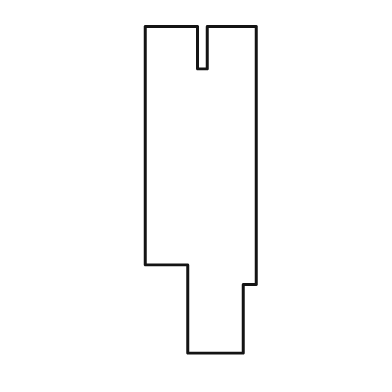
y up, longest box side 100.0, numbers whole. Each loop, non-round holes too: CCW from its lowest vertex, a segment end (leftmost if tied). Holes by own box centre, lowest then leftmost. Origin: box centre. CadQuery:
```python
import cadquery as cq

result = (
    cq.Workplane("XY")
    .moveTo(-4.0, -50.0)
    .lineTo(13.0, -50.0)
    .lineTo(13.0, -29.0)
    .lineTo(17.0, -29.0)
    .lineTo(17.0, 50.0)
    .lineTo(2.0, 50.0)
    .lineTo(2.0, 37.0)
    .lineTo(-1.0, 37.0)
    .lineTo(-1.0, 50.0)
    .lineTo(-17.0, 50.0)
    .lineTo(-17.0, -23.0)
    .lineTo(-4.0, -23.0)
    .close()
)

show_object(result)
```